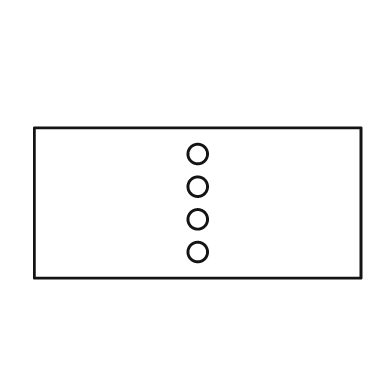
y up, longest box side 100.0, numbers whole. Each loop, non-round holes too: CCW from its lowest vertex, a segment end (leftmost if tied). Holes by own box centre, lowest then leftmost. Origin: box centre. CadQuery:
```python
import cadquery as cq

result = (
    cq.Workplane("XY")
    .moveTo(-50.0, -23.0)
    .lineTo(50.0, -23.0)
    .lineTo(50.0, 23.0)
    .lineTo(-50.0, 23.0)
    .close()
    .moveTo(0.0, -15.0)
    .circle(3.0)
    .moveTo(0.0, -5.0)
    .circle(3.0)
    .moveTo(0.0, 5.0)
    .circle(3.0)
    .moveTo(0.0, 15.0)
    .circle(3.0)
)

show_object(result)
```